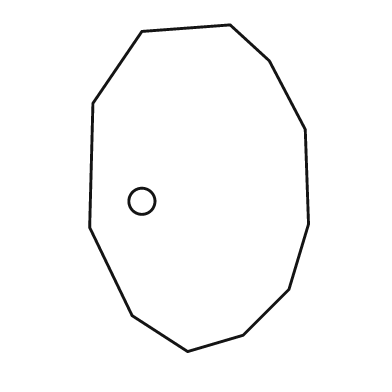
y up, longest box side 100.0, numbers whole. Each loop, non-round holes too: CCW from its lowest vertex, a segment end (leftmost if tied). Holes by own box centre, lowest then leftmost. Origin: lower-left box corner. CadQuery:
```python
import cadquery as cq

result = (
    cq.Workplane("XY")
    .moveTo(30.0, 0.0)
    .lineTo(47.0, 5.0)
    .lineTo(61.0, 19.0)
    .lineTo(67.0, 39.0)
    .lineTo(66.0, 68.0)
    .lineTo(55.0, 89.0)
    .lineTo(43.0, 100.0)
    .lineTo(16.0, 98.0)
    .lineTo(1.0, 76.0)
    .lineTo(0.0, 38.0)
    .lineTo(13.0, 11.0)
    .close()
    .moveTo(16.0, 46.0)
    .circle(4.0)
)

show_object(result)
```